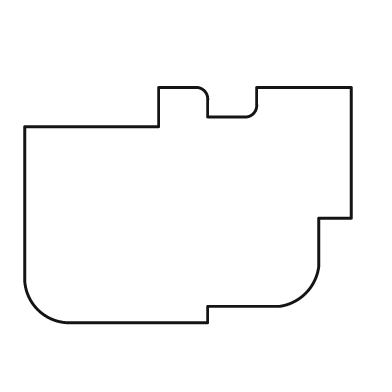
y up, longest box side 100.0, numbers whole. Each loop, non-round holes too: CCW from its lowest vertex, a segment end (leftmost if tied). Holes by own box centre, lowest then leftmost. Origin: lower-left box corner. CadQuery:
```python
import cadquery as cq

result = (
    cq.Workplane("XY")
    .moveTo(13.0, 0.0)
    .lineTo(56.0, 0.0)
    .lineTo(56.0, 5.0)
    .lineTo(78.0, 5.0)
    .threePointArc((86.0, 9.0), (90.0, 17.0))
    .lineTo(90.0, 32.0)
    .lineTo(100.0, 32.0)
    .lineTo(100.0, 72.0)
    .lineTo(71.0, 72.0)
    .lineTo(71.0, 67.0)
    .threePointArc((70.0, 64.0), (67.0, 63.0))
    .lineTo(56.0, 63.0)
    .lineTo(56.0, 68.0)
    .threePointArc((55.0, 71.0), (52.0, 72.0))
    .lineTo(41.0, 72.0)
    .lineTo(41.0, 60.0)
    .lineTo(0.0, 60.0)
    .lineTo(0.0, 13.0)
    .threePointArc((4.0, 4.0), (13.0, 0.0))
    .close()
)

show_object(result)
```